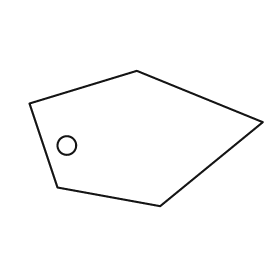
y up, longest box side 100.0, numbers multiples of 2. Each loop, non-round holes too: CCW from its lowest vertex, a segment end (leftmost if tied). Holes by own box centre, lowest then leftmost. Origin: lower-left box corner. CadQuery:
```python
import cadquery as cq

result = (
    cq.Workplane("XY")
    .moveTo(56.0, 0.0)
    .lineTo(100.0, 36.0)
    .lineTo(46.0, 58.0)
    .lineTo(0.0, 44.0)
    .lineTo(12.0, 8.0)
    .close()
    .moveTo(16.0, 26.0)
    .circle(4.0)
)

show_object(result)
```